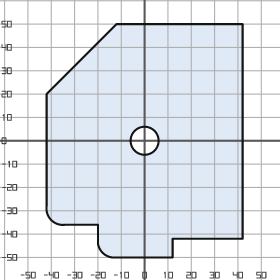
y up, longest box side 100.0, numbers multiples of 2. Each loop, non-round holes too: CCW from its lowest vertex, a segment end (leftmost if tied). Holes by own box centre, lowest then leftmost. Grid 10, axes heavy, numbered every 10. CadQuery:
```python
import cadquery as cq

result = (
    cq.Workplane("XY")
    .moveTo(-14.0, -50.0)
    .lineTo(12.0, -50.0)
    .lineTo(12.0, -42.0)
    .lineTo(42.0, -42.0)
    .lineTo(42.0, 50.0)
    .lineTo(-12.0, 50.0)
    .lineTo(-42.0, 20.0)
    .lineTo(-42.0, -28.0)
    .threePointArc((-40.0, -34.0), (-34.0, -36.0))
    .lineTo(-20.0, -36.0)
    .lineTo(-20.0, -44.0)
    .threePointArc((-18.0, -48.0), (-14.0, -50.0))
    .close()
    .moveTo(0.0, 0.0)
    .circle(6.0)
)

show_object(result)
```